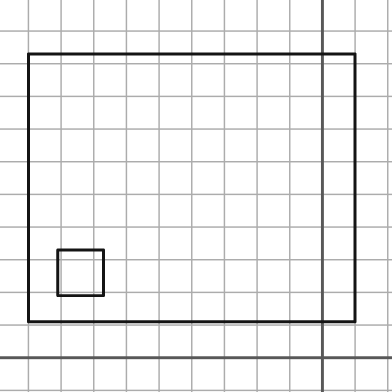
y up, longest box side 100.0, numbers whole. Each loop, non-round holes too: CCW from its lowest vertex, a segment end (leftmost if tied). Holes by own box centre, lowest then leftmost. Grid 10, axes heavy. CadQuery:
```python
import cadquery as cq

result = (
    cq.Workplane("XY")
    .moveTo(-90.0, 11.0)
    .lineTo(10.0, 11.0)
    .lineTo(10.0, 93.0)
    .lineTo(-90.0, 93.0)
    .close()
    .moveTo(-81.0, 19.0)
    .lineTo(-67.0, 19.0)
    .lineTo(-67.0, 33.0)
    .lineTo(-81.0, 33.0)
    .close()
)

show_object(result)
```